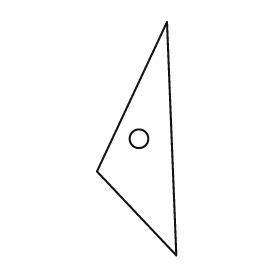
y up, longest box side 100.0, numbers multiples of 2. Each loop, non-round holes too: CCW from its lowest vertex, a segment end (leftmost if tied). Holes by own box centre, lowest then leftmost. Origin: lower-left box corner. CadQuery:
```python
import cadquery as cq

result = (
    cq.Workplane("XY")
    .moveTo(34.0, 0.0)
    .lineTo(30.0, 100.0)
    .lineTo(0.0, 36.0)
    .close()
    .moveTo(18.0, 50.0)
    .circle(4.0)
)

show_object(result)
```